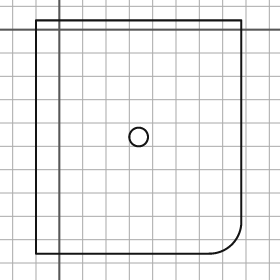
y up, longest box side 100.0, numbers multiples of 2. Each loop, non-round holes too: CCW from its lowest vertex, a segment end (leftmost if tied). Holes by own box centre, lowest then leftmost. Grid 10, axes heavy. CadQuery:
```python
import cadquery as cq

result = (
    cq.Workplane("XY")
    .moveTo(-10.0, -96.0)
    .lineTo(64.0, -96.0)
    .threePointArc((74.0, -92.0), (78.0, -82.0))
    .lineTo(78.0, 4.0)
    .lineTo(-10.0, 4.0)
    .close()
    .moveTo(34.0, -46.0)
    .circle(4.0)
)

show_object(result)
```